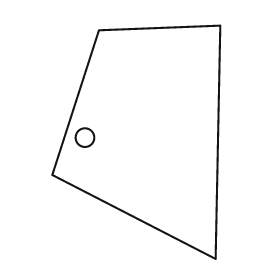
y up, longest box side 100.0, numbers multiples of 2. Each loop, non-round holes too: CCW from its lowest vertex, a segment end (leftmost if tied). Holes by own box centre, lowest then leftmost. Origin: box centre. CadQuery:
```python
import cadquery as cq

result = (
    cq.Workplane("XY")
    .moveTo(34.0, -50.0)
    .lineTo(36.0, 50.0)
    .lineTo(-16.0, 48.0)
    .lineTo(-36.0, -14.0)
    .close()
    .moveTo(-22.0, 2.0)
    .circle(4.0)
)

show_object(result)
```